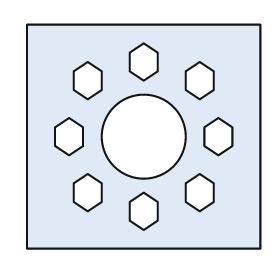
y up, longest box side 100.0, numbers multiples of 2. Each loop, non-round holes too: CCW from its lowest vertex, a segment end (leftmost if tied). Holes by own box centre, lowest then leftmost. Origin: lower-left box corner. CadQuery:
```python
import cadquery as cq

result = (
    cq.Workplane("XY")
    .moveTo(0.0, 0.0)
    .lineTo(100.0, 0.0)
    .lineTo(100.0, 96.0)
    .lineTo(0.0, 96.0)
    .close()
    .moveTo(50.0, 8.0)
    .lineTo(56.0, 12.0)
    .lineTo(56.0, 20.0)
    .lineTo(50.0, 24.0)
    .lineTo(44.0, 20.0)
    .lineTo(44.0, 12.0)
    .close()
    .moveTo(26.0, 16.0)
    .lineTo(32.0, 20.0)
    .lineTo(32.0, 28.0)
    .lineTo(26.0, 32.0)
    .lineTo(20.0, 28.0)
    .lineTo(20.0, 20.0)
    .close()
    .moveTo(74.0, 16.0)
    .lineTo(80.0, 20.0)
    .lineTo(80.0, 28.0)
    .lineTo(74.0, 32.0)
    .lineTo(68.0, 28.0)
    .lineTo(68.0, 20.0)
    .close()
    .moveTo(18.0, 40.0)
    .lineTo(24.0, 44.0)
    .lineTo(24.0, 52.0)
    .lineTo(18.0, 56.0)
    .lineTo(12.0, 52.0)
    .lineTo(12.0, 44.0)
    .close()
    .moveTo(50.0, 48.0)
    .circle(18.0)
    .moveTo(82.0, 40.0)
    .lineTo(88.0, 44.0)
    .lineTo(88.0, 52.0)
    .lineTo(82.0, 56.0)
    .lineTo(76.0, 52.0)
    .lineTo(76.0, 44.0)
    .close()
    .moveTo(26.0, 64.0)
    .lineTo(32.0, 68.0)
    .lineTo(32.0, 76.0)
    .lineTo(26.0, 80.0)
    .lineTo(20.0, 76.0)
    .lineTo(20.0, 68.0)
    .close()
    .moveTo(74.0, 64.0)
    .lineTo(80.0, 68.0)
    .lineTo(80.0, 76.0)
    .lineTo(74.0, 80.0)
    .lineTo(68.0, 76.0)
    .lineTo(68.0, 68.0)
    .close()
    .moveTo(50.0, 72.0)
    .lineTo(56.0, 76.0)
    .lineTo(56.0, 84.0)
    .lineTo(50.0, 88.0)
    .lineTo(44.0, 84.0)
    .lineTo(44.0, 76.0)
    .close()
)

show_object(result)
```